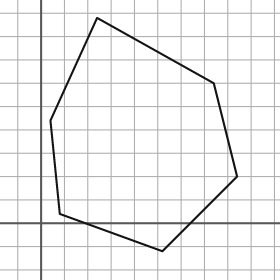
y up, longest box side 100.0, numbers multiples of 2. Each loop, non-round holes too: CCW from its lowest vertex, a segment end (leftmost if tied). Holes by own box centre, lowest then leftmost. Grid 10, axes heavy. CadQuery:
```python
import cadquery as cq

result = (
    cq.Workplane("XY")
    .moveTo(52.0, -12.0)
    .lineTo(84.0, 20.0)
    .lineTo(74.0, 60.0)
    .lineTo(24.0, 88.0)
    .lineTo(4.0, 44.0)
    .lineTo(8.0, 4.0)
    .close()
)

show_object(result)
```